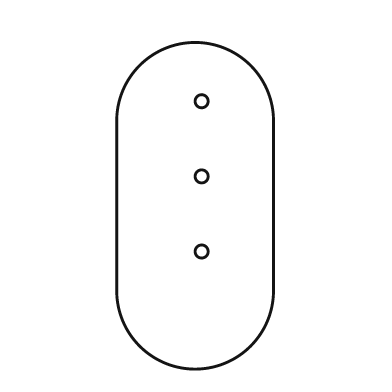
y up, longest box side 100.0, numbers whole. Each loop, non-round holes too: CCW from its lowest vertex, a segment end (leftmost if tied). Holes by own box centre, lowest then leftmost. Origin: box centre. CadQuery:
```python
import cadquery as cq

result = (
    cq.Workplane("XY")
    .moveTo(-24.0, -26.0)
    .threePointArc((0.0, -50.0), (24.0, -26.0))
    .lineTo(24.0, 26.0)
    .threePointArc((0.0, 50.0), (-24.0, 26.0))
    .close()
    .moveTo(2.0, -14.0)
    .circle(2.0)
    .moveTo(2.0, 9.0)
    .circle(2.0)
    .moveTo(2.0, 32.0)
    .circle(2.0)
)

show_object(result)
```